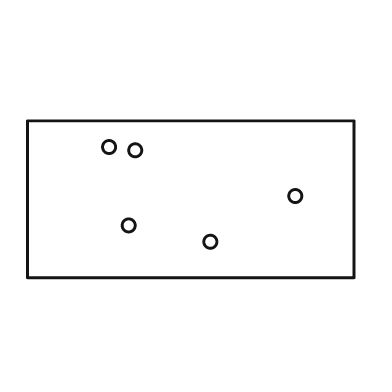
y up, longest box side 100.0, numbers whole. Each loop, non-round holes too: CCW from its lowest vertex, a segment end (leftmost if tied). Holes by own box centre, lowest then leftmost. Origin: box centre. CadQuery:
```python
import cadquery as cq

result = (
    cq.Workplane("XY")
    .moveTo(-50.0, -24.0)
    .lineTo(50.0, -24.0)
    .lineTo(50.0, 24.0)
    .lineTo(-50.0, 24.0)
    .close()
    .moveTo(6.0, -13.0)
    .circle(2.0)
    .moveTo(-19.0, -8.0)
    .circle(2.0)
    .moveTo(32.0, 1.0)
    .circle(2.0)
    .moveTo(-17.0, 15.0)
    .circle(2.0)
    .moveTo(-25.0, 16.0)
    .circle(2.0)
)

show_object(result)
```